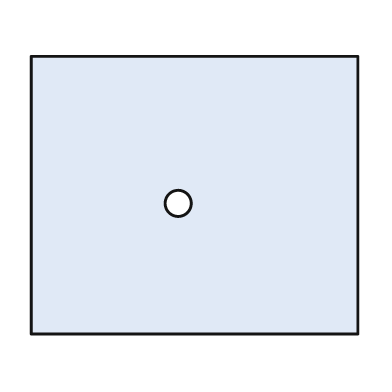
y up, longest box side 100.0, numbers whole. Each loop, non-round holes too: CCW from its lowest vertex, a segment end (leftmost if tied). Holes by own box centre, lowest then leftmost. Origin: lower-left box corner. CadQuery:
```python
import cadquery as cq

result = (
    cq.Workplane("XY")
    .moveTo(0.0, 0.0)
    .lineTo(100.0, 0.0)
    .lineTo(100.0, 85.0)
    .lineTo(0.0, 85.0)
    .close()
    .moveTo(45.0, 40.0)
    .circle(4.0)
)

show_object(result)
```